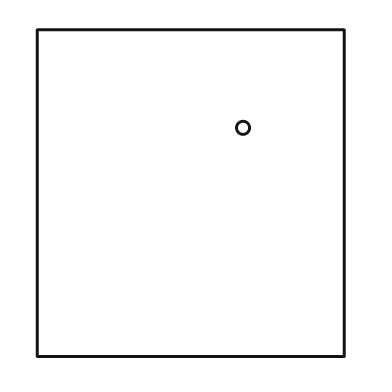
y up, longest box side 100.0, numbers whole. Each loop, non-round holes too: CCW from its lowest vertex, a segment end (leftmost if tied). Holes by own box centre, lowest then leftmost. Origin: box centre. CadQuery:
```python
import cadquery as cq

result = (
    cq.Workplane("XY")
    .moveTo(-47.0, -50.0)
    .lineTo(47.0, -50.0)
    .lineTo(47.0, 50.0)
    .lineTo(-47.0, 50.0)
    .close()
    .moveTo(16.0, 20.0)
    .circle(2.0)
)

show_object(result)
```